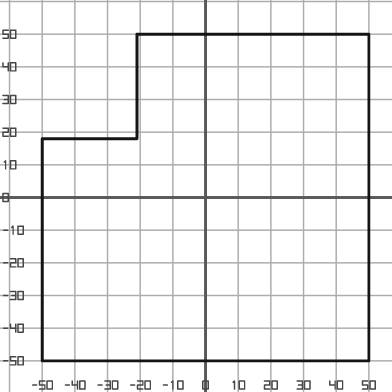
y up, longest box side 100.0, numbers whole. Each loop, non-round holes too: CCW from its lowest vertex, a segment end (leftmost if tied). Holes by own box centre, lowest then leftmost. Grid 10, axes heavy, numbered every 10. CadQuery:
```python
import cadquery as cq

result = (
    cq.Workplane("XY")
    .moveTo(-50.0, -50.0)
    .lineTo(50.0, -50.0)
    .lineTo(50.0, 50.0)
    .lineTo(-21.0, 50.0)
    .lineTo(-21.0, 18.0)
    .lineTo(-50.0, 18.0)
    .close()
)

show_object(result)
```